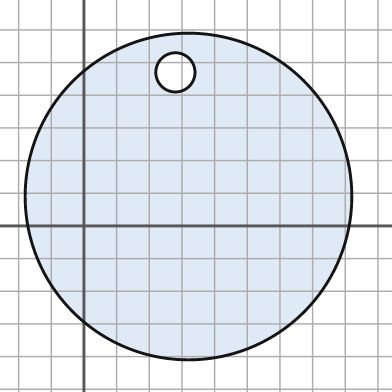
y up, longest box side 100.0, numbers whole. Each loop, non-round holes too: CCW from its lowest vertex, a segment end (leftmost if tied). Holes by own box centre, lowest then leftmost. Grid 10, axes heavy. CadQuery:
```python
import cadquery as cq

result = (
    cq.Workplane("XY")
    .moveTo(32.0, 9.0)
    .circle(50.0)
    .moveTo(28.0, 47.0)
    .circle(6.0)
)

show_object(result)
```